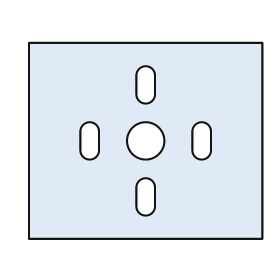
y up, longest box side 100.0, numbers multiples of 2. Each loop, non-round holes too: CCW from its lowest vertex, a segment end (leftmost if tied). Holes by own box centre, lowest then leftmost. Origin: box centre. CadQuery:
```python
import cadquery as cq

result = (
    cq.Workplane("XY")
    .moveTo(-50.0, -42.0)
    .lineTo(50.0, -42.0)
    .lineTo(50.0, 42.0)
    .lineTo(-50.0, 42.0)
    .close()
    .moveTo(-4.0, -28.0)
    .threePointArc((0.0, -32.0), (4.0, -28.0))
    .lineTo(4.0, -20.0)
    .threePointArc((0.0, -16.0), (-4.0, -20.0))
    .close()
    .moveTo(-28.0, -4.0)
    .threePointArc((-24.0, -8.0), (-20.0, -4.0))
    .lineTo(-20.0, 4.0)
    .threePointArc((-24.0, 8.0), (-28.0, 4.0))
    .close()
    .moveTo(0.0, 0.0)
    .circle(8.0)
    .moveTo(20.0, -4.0)
    .threePointArc((24.0, -8.0), (28.0, -4.0))
    .lineTo(28.0, 4.0)
    .threePointArc((24.0, 8.0), (20.0, 4.0))
    .close()
    .moveTo(-4.0, 20.0)
    .threePointArc((0.0, 16.0), (4.0, 20.0))
    .lineTo(4.0, 28.0)
    .threePointArc((0.0, 32.0), (-4.0, 28.0))
    .close()
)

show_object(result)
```